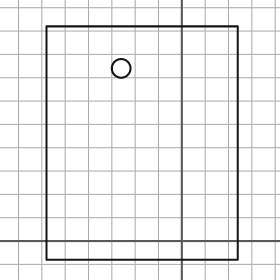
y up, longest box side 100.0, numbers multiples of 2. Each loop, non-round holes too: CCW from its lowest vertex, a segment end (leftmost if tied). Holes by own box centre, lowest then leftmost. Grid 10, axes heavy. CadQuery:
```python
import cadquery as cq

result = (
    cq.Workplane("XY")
    .moveTo(-58.0, -8.0)
    .lineTo(24.0, -8.0)
    .lineTo(24.0, 92.0)
    .lineTo(-58.0, 92.0)
    .close()
    .moveTo(-26.0, 74.0)
    .circle(4.0)
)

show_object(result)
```